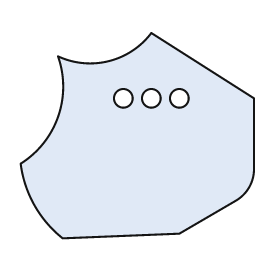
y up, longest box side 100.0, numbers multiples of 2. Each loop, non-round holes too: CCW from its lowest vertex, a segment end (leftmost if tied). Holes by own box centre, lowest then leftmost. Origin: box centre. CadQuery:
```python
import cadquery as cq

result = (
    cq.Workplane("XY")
    .moveTo(-32.0, -44.0)
    .lineTo(18.0, -42.0)
    .lineTo(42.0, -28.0)
    .threePointArc((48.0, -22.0), (50.0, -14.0))
    .lineTo(50.0, 16.0)
    .lineTo(6.0, 44.0)
    .threePointArc((-12.0, 32.0), (-34.0, 34.0))
    .threePointArc((-34.0, 8.0), (-50.0, -12.0))
    .threePointArc((-44.0, -30.0), (-32.0, -44.0))
    .close()
    .moveTo(-6.0, 16.0)
    .circle(4.0)
    .moveTo(6.0, 16.0)
    .circle(4.0)
    .moveTo(18.0, 16.0)
    .circle(4.0)
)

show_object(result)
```